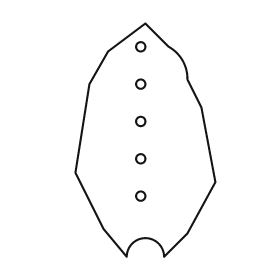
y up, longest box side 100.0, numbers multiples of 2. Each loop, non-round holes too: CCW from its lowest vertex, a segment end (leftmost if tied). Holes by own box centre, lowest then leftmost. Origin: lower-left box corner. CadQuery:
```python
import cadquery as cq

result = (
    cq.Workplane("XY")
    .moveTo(22.0, 0.0)
    .threePointArc((30.0, 8.0), (38.0, 0.0))
    .lineTo(48.0, 10.0)
    .lineTo(60.0, 32.0)
    .lineTo(54.0, 64.0)
    .lineTo(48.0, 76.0)
    .threePointArc((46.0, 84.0), (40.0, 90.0))
    .lineTo(30.0, 100.0)
    .lineTo(14.0, 88.0)
    .lineTo(6.0, 74.0)
    .lineTo(0.0, 36.0)
    .lineTo(12.0, 12.0)
    .close()
    .moveTo(28.0, 26.0)
    .circle(2.0)
    .moveTo(28.0, 42.0)
    .circle(2.0)
    .moveTo(28.0, 58.0)
    .circle(2.0)
    .moveTo(28.0, 74.0)
    .circle(2.0)
    .moveTo(28.0, 90.0)
    .circle(2.0)
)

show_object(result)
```